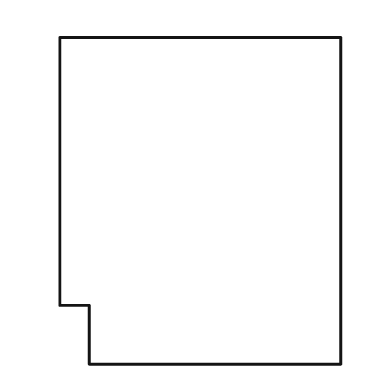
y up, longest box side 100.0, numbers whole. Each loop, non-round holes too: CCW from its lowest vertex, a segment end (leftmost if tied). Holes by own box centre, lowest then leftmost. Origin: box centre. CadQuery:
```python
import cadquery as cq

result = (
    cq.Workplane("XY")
    .moveTo(-34.0, -50.0)
    .lineTo(43.0, -50.0)
    .lineTo(43.0, 50.0)
    .lineTo(-43.0, 50.0)
    .lineTo(-43.0, -32.0)
    .lineTo(-34.0, -32.0)
    .close()
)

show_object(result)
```